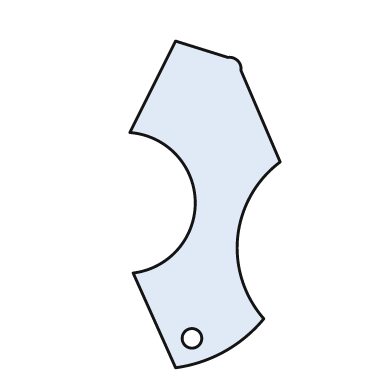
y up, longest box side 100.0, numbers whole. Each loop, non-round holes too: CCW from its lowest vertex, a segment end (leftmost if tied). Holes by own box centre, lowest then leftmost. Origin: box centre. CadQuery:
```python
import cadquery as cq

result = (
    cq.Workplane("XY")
    .moveTo(-9.0, -50.0)
    .threePointArc((6.0, -45.0), (18.0, -35.0))
    .threePointArc((10.0, -10.0), (23.0, 13.0))
    .lineTo(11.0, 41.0)
    .threePointArc((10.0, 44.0), (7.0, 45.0))
    .lineTo(-9.0, 50.0)
    .lineTo(-23.0, 22.0)
    .threePointArc((-3.0, 1.0), (-22.0, -21.0))
    .close()
    .moveTo(-4.0, -41.0)
    .circle(3.0)
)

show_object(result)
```